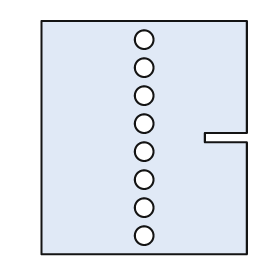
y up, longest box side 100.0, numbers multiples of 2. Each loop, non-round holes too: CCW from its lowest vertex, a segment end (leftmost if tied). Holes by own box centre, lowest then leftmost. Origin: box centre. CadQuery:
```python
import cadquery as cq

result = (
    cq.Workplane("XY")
    .moveTo(-44.0, -50.0)
    .lineTo(44.0, -50.0)
    .lineTo(44.0, -2.0)
    .lineTo(26.0, -2.0)
    .lineTo(26.0, 2.0)
    .lineTo(44.0, 2.0)
    .lineTo(44.0, 50.0)
    .lineTo(-44.0, 50.0)
    .close()
    .moveTo(0.0, -42.0)
    .circle(4.0)
    .moveTo(0.0, -30.0)
    .circle(4.0)
    .moveTo(0.0, -18.0)
    .circle(4.0)
    .moveTo(0.0, -6.0)
    .circle(4.0)
    .moveTo(0.0, 6.0)
    .circle(4.0)
    .moveTo(0.0, 18.0)
    .circle(4.0)
    .moveTo(0.0, 30.0)
    .circle(4.0)
    .moveTo(0.0, 42.0)
    .circle(4.0)
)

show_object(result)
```